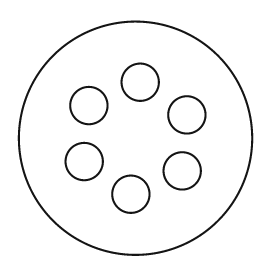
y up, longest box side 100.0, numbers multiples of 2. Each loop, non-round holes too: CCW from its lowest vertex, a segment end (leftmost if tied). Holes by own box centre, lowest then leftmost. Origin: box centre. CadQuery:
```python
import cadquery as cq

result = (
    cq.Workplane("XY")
    .moveTo(0.0, 0.0)
    .circle(50.0)
    .moveTo(-2.0, -24.0)
    .circle(8.0)
    .moveTo(20.0, -14.0)
    .circle(8.0)
    .moveTo(-22.0, -10.0)
    .circle(8.0)
    .moveTo(22.0, 10.0)
    .circle(8.0)
    .moveTo(-20.0, 14.0)
    .circle(8.0)
    .moveTo(2.0, 24.0)
    .circle(8.0)
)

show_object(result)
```